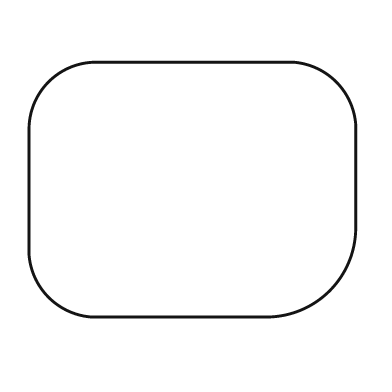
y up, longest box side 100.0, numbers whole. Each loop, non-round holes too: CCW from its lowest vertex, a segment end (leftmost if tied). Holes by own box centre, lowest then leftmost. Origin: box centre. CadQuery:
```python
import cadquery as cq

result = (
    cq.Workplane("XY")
    .moveTo(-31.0, -39.0)
    .lineTo(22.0, -39.0)
    .threePointArc((42.0, -31.0), (50.0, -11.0))
    .lineTo(50.0, 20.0)
    .threePointArc((44.0, 33.0), (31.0, 39.0))
    .lineTo(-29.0, 39.0)
    .threePointArc((-44.0, 33.0), (-50.0, 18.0))
    .lineTo(-50.0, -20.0)
    .threePointArc((-44.0, -33.0), (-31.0, -39.0))
    .close()
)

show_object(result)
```